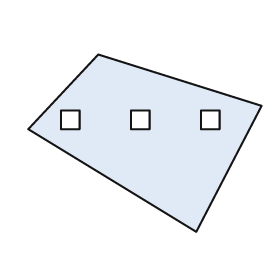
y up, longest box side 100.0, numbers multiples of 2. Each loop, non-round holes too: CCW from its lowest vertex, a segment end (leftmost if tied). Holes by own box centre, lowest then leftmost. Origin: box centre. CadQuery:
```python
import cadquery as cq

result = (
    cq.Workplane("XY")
    .moveTo(22.0, -38.0)
    .lineTo(50.0, 16.0)
    .lineTo(-20.0, 38.0)
    .lineTo(-50.0, 6.0)
    .close()
    .moveTo(-36.0, 6.0)
    .lineTo(-28.0, 6.0)
    .lineTo(-28.0, 14.0)
    .lineTo(-36.0, 14.0)
    .close()
    .moveTo(-6.0, 6.0)
    .lineTo(2.0, 6.0)
    .lineTo(2.0, 14.0)
    .lineTo(-6.0, 14.0)
    .close()
    .moveTo(24.0, 6.0)
    .lineTo(32.0, 6.0)
    .lineTo(32.0, 14.0)
    .lineTo(24.0, 14.0)
    .close()
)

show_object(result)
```